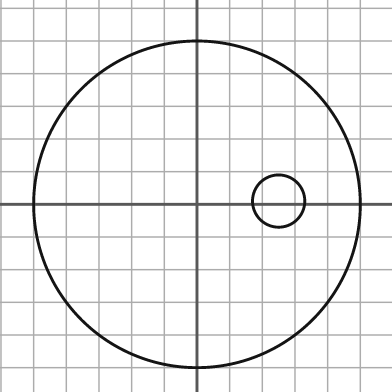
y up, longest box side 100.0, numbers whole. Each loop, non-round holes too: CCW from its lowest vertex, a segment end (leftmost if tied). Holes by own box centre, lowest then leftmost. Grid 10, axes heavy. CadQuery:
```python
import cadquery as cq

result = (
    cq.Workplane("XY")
    .moveTo(0.0, 0.0)
    .circle(50.0)
    .moveTo(25.0, 1.0)
    .circle(8.0)
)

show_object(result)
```